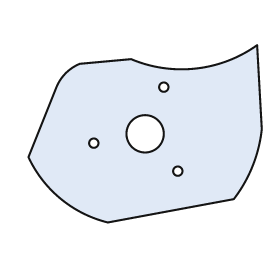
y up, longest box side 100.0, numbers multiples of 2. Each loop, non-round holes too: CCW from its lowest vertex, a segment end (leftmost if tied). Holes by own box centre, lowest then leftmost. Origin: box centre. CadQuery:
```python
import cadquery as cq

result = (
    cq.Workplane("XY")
    .moveTo(-16.0, -38.0)
    .lineTo(38.0, -28.0)
    .threePointArc((46.0, -14.0), (50.0, 2.0))
    .lineTo(48.0, 38.0)
    .threePointArc((22.0, 28.0), (-6.0, 32.0))
    .lineTo(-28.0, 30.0)
    .threePointArc((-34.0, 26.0), (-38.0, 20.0))
    .lineTo(-50.0, -10.0)
    .threePointArc((-36.0, -28.0), (-16.0, -38.0))
    .close()
    .moveTo(14.0, -16.0)
    .circle(2.0)
    .moveTo(-22.0, -4.0)
    .circle(2.0)
    .moveTo(0.0, 0.0)
    .circle(8.0)
    .moveTo(8.0, 20.0)
    .circle(2.0)
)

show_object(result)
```